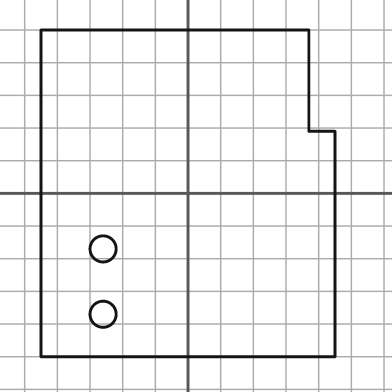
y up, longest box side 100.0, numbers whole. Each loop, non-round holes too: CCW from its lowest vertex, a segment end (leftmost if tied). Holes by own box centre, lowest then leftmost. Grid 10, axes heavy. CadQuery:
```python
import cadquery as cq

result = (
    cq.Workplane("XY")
    .moveTo(-45.0, -50.0)
    .lineTo(45.0, -50.0)
    .lineTo(45.0, 19.0)
    .lineTo(37.0, 19.0)
    .lineTo(37.0, 50.0)
    .lineTo(-45.0, 50.0)
    .close()
    .moveTo(-26.0, -37.0)
    .circle(4.0)
    .moveTo(-26.0, -17.0)
    .circle(4.0)
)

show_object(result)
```